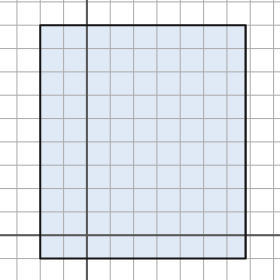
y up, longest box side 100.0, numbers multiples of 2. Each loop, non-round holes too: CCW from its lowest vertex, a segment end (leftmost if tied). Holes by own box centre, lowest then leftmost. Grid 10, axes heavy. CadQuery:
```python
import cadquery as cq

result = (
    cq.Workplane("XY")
    .moveTo(-20.0, -10.0)
    .lineTo(68.0, -10.0)
    .lineTo(68.0, 90.0)
    .lineTo(-20.0, 90.0)
    .close()
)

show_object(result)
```